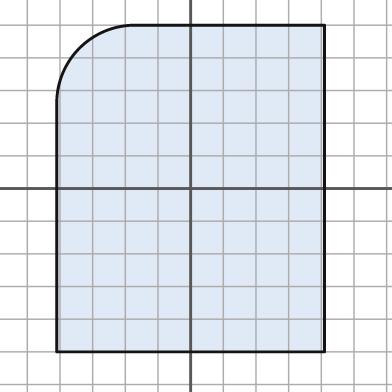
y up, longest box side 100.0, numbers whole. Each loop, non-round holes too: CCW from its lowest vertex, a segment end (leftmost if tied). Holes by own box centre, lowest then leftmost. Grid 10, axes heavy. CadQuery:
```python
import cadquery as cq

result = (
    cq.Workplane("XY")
    .moveTo(-41.0, -50.0)
    .lineTo(41.0, -50.0)
    .lineTo(41.0, 50.0)
    .lineTo(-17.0, 50.0)
    .threePointArc((-34.0, 43.0), (-41.0, 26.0))
    .close()
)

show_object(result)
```